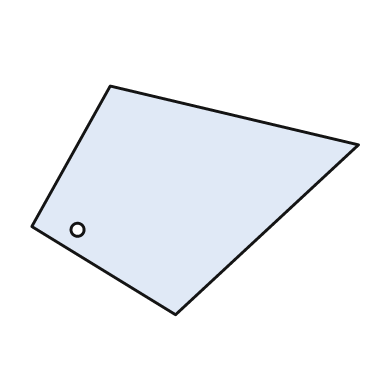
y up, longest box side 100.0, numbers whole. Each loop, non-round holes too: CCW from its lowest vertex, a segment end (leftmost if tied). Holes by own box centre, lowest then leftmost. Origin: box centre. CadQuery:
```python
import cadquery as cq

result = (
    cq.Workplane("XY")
    .moveTo(-6.0, -35.0)
    .lineTo(50.0, 17.0)
    .lineTo(-26.0, 35.0)
    .lineTo(-50.0, -8.0)
    .close()
    .moveTo(-36.0, -9.0)
    .circle(2.0)
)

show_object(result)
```